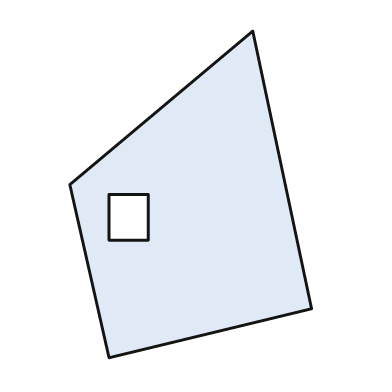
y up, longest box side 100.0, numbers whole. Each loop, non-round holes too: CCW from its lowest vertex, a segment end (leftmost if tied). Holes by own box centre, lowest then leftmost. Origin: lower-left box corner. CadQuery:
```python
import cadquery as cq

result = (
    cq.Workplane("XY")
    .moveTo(12.0, 0.0)
    .lineTo(74.0, 15.0)
    .lineTo(56.0, 100.0)
    .lineTo(0.0, 53.0)
    .close()
    .moveTo(12.0, 36.0)
    .lineTo(24.0, 36.0)
    .lineTo(24.0, 50.0)
    .lineTo(12.0, 50.0)
    .close()
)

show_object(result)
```